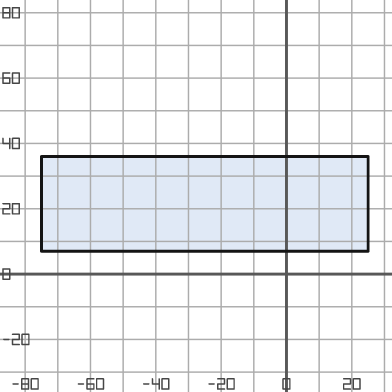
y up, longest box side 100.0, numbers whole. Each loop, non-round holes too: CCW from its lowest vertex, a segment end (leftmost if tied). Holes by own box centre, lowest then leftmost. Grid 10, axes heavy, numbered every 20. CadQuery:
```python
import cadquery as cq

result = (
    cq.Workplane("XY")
    .moveTo(-75.0, 7.0)
    .lineTo(25.0, 7.0)
    .lineTo(25.0, 36.0)
    .lineTo(-75.0, 36.0)
    .close()
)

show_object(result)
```